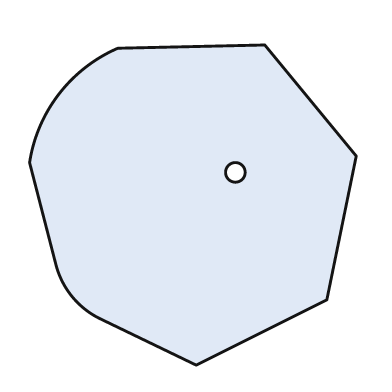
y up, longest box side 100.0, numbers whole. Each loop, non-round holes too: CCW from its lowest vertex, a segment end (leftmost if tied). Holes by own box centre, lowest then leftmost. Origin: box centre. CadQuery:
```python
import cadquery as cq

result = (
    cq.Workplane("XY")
    .moveTo(1.0, -49.0)
    .lineTo(41.0, -29.0)
    .lineTo(50.0, 15.0)
    .lineTo(22.0, 49.0)
    .lineTo(-23.0, 48.0)
    .threePointArc((-41.0, 34.0), (-50.0, 13.0))
    .lineTo(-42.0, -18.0)
    .threePointArc((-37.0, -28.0), (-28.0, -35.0))
    .close()
    .moveTo(13.0, 10.0)
    .circle(3.0)
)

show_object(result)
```